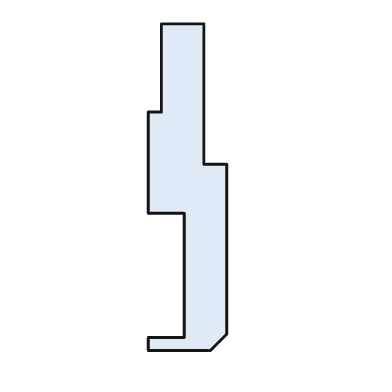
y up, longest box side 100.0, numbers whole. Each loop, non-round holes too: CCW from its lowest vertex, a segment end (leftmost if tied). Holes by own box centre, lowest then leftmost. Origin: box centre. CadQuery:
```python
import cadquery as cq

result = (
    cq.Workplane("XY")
    .moveTo(-12.0, -50.0)
    .lineTo(7.0, -50.0)
    .lineTo(12.0, -45.0)
    .lineTo(12.0, 7.0)
    .lineTo(5.0, 7.0)
    .lineTo(5.0, 50.0)
    .lineTo(-8.0, 50.0)
    .lineTo(-8.0, 23.0)
    .lineTo(-12.0, 23.0)
    .lineTo(-12.0, -8.0)
    .lineTo(-1.0, -8.0)
    .lineTo(-1.0, -46.0)
    .lineTo(-12.0, -46.0)
    .close()
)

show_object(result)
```